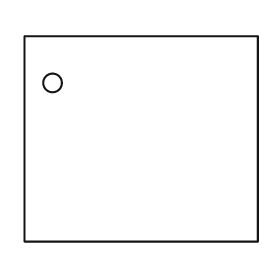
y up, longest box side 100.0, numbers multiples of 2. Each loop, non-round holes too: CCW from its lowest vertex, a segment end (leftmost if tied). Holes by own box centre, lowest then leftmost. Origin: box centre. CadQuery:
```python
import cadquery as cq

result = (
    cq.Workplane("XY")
    .moveTo(-50.0, -44.0)
    .lineTo(50.0, -44.0)
    .lineTo(50.0, 44.0)
    .lineTo(-50.0, 44.0)
    .close()
    .moveTo(-38.0, 24.0)
    .circle(4.0)
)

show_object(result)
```